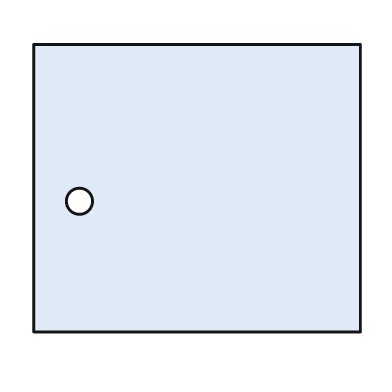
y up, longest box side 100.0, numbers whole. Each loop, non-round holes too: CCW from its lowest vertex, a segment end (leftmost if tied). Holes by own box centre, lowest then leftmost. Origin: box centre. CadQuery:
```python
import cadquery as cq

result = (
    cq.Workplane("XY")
    .moveTo(-50.0, -44.0)
    .lineTo(50.0, -44.0)
    .lineTo(50.0, 44.0)
    .lineTo(-50.0, 44.0)
    .close()
    .moveTo(-36.0, -4.0)
    .circle(4.0)
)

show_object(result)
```